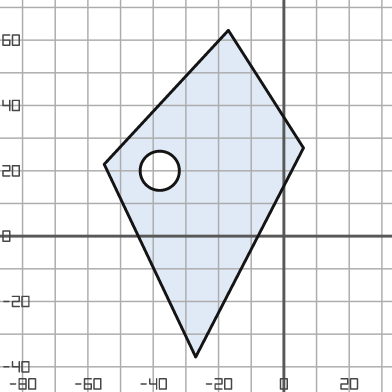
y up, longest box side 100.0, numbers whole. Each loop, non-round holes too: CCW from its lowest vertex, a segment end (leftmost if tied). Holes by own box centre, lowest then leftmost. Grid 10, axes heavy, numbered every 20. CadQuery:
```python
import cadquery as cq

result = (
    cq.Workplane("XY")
    .moveTo(-27.0, -37.0)
    .lineTo(6.0, 27.0)
    .lineTo(-17.0, 63.0)
    .lineTo(-55.0, 22.0)
    .close()
    .moveTo(-38.0, 20.0)
    .circle(6.0)
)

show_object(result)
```